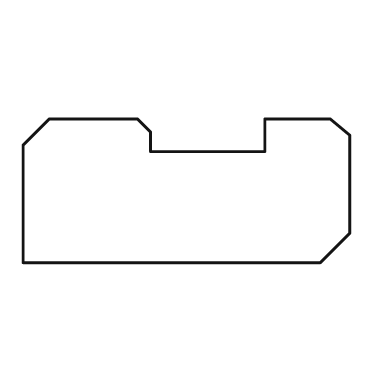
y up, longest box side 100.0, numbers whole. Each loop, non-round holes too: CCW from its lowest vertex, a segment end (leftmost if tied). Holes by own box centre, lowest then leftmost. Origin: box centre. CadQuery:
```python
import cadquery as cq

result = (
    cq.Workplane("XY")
    .moveTo(-50.0, -22.0)
    .lineTo(41.0, -22.0)
    .lineTo(50.0, -13.0)
    .lineTo(50.0, 17.0)
    .lineTo(44.0, 22.0)
    .lineTo(24.0, 22.0)
    .lineTo(24.0, 12.0)
    .lineTo(-11.0, 12.0)
    .lineTo(-11.0, 18.0)
    .lineTo(-15.0, 22.0)
    .lineTo(-42.0, 22.0)
    .lineTo(-50.0, 14.0)
    .close()
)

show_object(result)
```